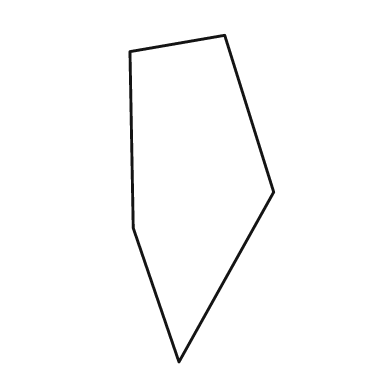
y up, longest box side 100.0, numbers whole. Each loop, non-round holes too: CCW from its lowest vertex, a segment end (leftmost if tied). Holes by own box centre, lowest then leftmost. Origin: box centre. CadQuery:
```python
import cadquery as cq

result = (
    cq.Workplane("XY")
    .moveTo(-7.0, -50.0)
    .lineTo(22.0, 2.0)
    .lineTo(7.0, 50.0)
    .lineTo(-22.0, 45.0)
    .lineTo(-21.0, -9.0)
    .close()
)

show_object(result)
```